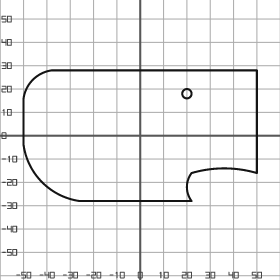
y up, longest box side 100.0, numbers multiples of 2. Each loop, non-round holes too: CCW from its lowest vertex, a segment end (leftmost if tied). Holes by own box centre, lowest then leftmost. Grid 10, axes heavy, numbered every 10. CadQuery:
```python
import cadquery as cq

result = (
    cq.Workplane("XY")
    .moveTo(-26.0, -28.0)
    .lineTo(22.0, -28.0)
    .threePointArc((20.0, -22.0), (22.0, -16.0))
    .threePointArc((36.0, -14.0), (50.0, -16.0))
    .lineTo(50.0, 28.0)
    .lineTo(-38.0, 28.0)
    .threePointArc((-46.0, 24.0), (-50.0, 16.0))
    .lineTo(-50.0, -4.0)
    .threePointArc((-42.0, -20.0), (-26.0, -28.0))
    .close()
    .moveTo(20.0, 18.0)
    .circle(2.0)
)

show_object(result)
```